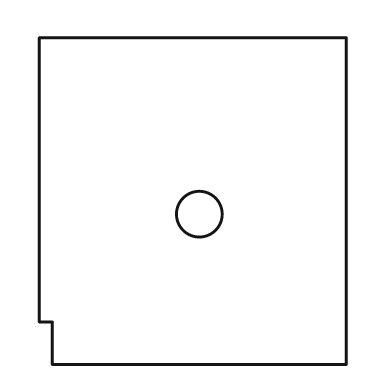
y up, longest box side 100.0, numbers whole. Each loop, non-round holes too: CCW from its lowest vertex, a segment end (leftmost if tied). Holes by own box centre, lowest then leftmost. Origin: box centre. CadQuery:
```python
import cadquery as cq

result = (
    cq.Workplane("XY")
    .moveTo(-43.0, -50.0)
    .lineTo(47.0, -50.0)
    .lineTo(47.0, 50.0)
    .lineTo(-47.0, 50.0)
    .lineTo(-47.0, -37.0)
    .lineTo(-43.0, -37.0)
    .close()
    .moveTo(2.0, -4.0)
    .circle(7.0)
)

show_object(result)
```